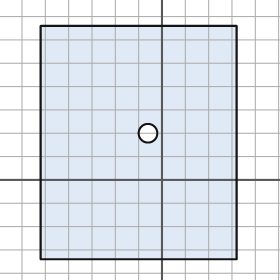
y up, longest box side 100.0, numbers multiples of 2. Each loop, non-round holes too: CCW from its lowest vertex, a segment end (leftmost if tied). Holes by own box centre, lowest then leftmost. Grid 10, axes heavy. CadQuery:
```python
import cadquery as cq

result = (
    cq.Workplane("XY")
    .moveTo(-52.0, -34.0)
    .lineTo(32.0, -34.0)
    .lineTo(32.0, 66.0)
    .lineTo(-52.0, 66.0)
    .close()
    .moveTo(-6.0, 20.0)
    .circle(4.0)
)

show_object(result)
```